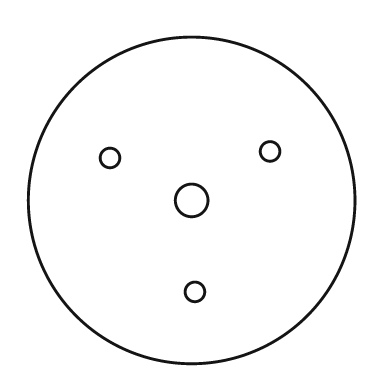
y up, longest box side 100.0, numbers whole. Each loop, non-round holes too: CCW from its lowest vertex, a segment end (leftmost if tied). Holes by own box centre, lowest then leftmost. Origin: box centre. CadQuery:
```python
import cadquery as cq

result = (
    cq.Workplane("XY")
    .moveTo(0.0, 0.0)
    .circle(50.0)
    .moveTo(1.0, -28.0)
    .circle(3.0)
    .moveTo(0.0, 0.0)
    .circle(5.0)
    .moveTo(-25.0, 13.0)
    .circle(3.0)
    .moveTo(24.0, 15.0)
    .circle(3.0)
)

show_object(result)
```